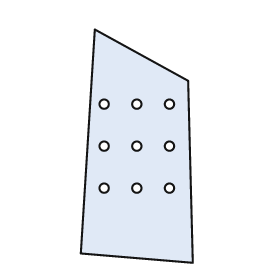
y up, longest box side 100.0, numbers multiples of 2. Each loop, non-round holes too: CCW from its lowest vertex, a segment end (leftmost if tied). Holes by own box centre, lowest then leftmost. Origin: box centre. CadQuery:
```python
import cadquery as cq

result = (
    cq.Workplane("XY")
    .moveTo(24.0, -50.0)
    .lineTo(22.0, 28.0)
    .lineTo(-18.0, 50.0)
    .lineTo(-24.0, -46.0)
    .close()
    .moveTo(-14.0, -18.0)
    .circle(2.0)
    .moveTo(0.0, -18.0)
    .circle(2.0)
    .moveTo(14.0, -18.0)
    .circle(2.0)
    .moveTo(-14.0, 0.0)
    .circle(2.0)
    .moveTo(0.0, 0.0)
    .circle(2.0)
    .moveTo(14.0, 0.0)
    .circle(2.0)
    .moveTo(-14.0, 18.0)
    .circle(2.0)
    .moveTo(0.0, 18.0)
    .circle(2.0)
    .moveTo(14.0, 18.0)
    .circle(2.0)
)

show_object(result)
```